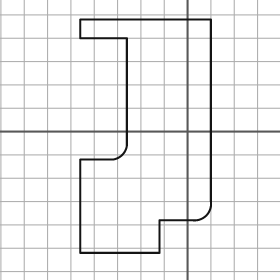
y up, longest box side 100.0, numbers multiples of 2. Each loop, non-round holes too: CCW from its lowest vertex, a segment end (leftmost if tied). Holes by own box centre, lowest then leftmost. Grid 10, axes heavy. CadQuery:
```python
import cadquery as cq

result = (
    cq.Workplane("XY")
    .moveTo(-46.0, -52.0)
    .lineTo(-12.0, -52.0)
    .lineTo(-12.0, -38.0)
    .lineTo(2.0, -38.0)
    .threePointArc((8.0, -36.0), (10.0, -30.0))
    .lineTo(10.0, 48.0)
    .lineTo(-46.0, 48.0)
    .lineTo(-46.0, 40.0)
    .lineTo(-26.0, 40.0)
    .lineTo(-26.0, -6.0)
    .threePointArc((-28.0, -10.0), (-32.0, -12.0))
    .lineTo(-46.0, -12.0)
    .close()
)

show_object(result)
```